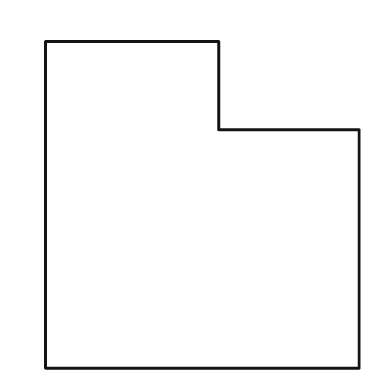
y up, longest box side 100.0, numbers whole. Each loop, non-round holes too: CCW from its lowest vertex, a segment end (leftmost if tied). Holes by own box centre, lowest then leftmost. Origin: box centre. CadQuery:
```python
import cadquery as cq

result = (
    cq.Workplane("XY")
    .moveTo(-48.0, -50.0)
    .lineTo(48.0, -50.0)
    .lineTo(48.0, 23.0)
    .lineTo(5.0, 23.0)
    .lineTo(5.0, 50.0)
    .lineTo(-48.0, 50.0)
    .close()
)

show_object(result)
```